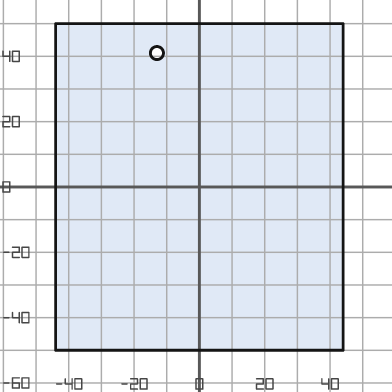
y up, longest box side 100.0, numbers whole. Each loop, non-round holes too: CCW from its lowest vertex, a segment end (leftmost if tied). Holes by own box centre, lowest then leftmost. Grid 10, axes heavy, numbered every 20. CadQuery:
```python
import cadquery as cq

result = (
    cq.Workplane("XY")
    .moveTo(-44.0, -50.0)
    .lineTo(44.0, -50.0)
    .lineTo(44.0, 50.0)
    .lineTo(-44.0, 50.0)
    .close()
    .moveTo(-13.0, 41.0)
    .circle(2.0)
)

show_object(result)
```